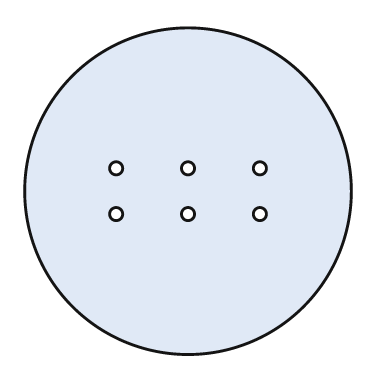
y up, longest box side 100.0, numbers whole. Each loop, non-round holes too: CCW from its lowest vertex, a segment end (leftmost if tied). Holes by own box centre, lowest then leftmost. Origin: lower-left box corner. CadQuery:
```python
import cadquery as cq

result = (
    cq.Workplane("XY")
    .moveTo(50.0, 50.0)
    .circle(50.0)
    .moveTo(28.0, 43.0)
    .circle(2.0)
    .moveTo(50.0, 43.0)
    .circle(2.0)
    .moveTo(72.0, 43.0)
    .circle(2.0)
    .moveTo(28.0, 57.0)
    .circle(2.0)
    .moveTo(50.0, 57.0)
    .circle(2.0)
    .moveTo(72.0, 57.0)
    .circle(2.0)
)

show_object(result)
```